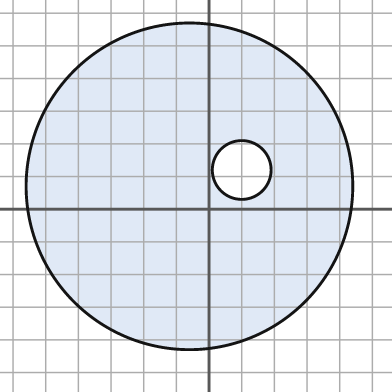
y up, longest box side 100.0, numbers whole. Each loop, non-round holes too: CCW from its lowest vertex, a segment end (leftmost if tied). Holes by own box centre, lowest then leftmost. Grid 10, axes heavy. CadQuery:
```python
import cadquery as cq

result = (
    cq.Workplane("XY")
    .moveTo(-6.0, 7.0)
    .circle(50.0)
    .moveTo(10.0, 12.0)
    .circle(9.0)
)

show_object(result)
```